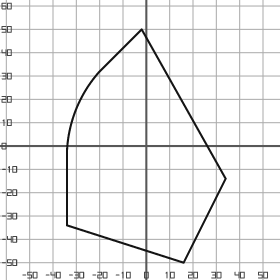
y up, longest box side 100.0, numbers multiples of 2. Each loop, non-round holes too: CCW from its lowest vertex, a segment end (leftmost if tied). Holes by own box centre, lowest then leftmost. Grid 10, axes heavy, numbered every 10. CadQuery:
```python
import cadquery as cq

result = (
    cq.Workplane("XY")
    .moveTo(16.0, -50.0)
    .lineTo(34.0, -14.0)
    .lineTo(-2.0, 50.0)
    .lineTo(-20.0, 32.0)
    .threePointArc((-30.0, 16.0), (-34.0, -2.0))
    .lineTo(-34.0, -34.0)
    .close()
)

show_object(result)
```